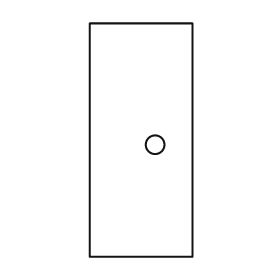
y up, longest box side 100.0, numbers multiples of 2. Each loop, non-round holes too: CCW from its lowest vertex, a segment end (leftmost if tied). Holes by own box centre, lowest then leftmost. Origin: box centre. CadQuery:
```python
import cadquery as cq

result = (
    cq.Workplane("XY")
    .moveTo(-22.0, -50.0)
    .lineTo(22.0, -50.0)
    .lineTo(22.0, 50.0)
    .lineTo(-22.0, 50.0)
    .close()
    .moveTo(6.0, -2.0)
    .circle(4.0)
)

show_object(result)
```